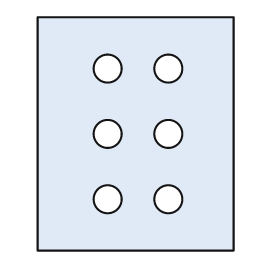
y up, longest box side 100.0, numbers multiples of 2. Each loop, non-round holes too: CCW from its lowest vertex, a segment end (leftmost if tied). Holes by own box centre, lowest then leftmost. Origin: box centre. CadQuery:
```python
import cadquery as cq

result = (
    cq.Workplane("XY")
    .moveTo(-42.0, -50.0)
    .lineTo(42.0, -50.0)
    .lineTo(42.0, 50.0)
    .lineTo(-42.0, 50.0)
    .close()
    .moveTo(-12.0, -28.0)
    .circle(6.0)
    .moveTo(14.0, -28.0)
    .circle(6.0)
    .moveTo(-12.0, 0.0)
    .circle(6.0)
    .moveTo(14.0, 0.0)
    .circle(6.0)
    .moveTo(-12.0, 28.0)
    .circle(6.0)
    .moveTo(14.0, 28.0)
    .circle(6.0)
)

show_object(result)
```